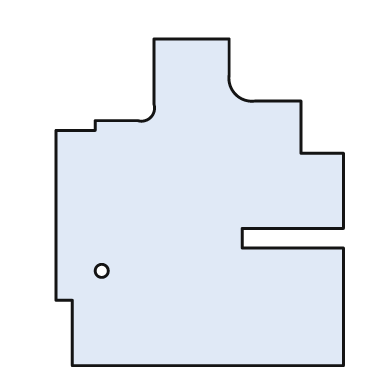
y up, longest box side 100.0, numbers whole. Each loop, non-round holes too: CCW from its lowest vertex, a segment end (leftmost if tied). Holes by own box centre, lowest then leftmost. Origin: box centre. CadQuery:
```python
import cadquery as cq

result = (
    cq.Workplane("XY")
    .moveTo(-39.0, -50.0)
    .lineTo(44.0, -50.0)
    .lineTo(44.0, -14.0)
    .lineTo(13.0, -14.0)
    .lineTo(13.0, -8.0)
    .lineTo(44.0, -8.0)
    .lineTo(44.0, 15.0)
    .lineTo(31.0, 15.0)
    .lineTo(31.0, 31.0)
    .lineTo(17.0, 31.0)
    .threePointArc((11.0, 33.0), (9.0, 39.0))
    .lineTo(9.0, 50.0)
    .lineTo(-14.0, 50.0)
    .lineTo(-14.0, 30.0)
    .threePointArc((-15.0, 26.0), (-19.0, 25.0))
    .lineTo(-32.0, 25.0)
    .lineTo(-32.0, 22.0)
    .lineTo(-44.0, 22.0)
    .lineTo(-44.0, -30.0)
    .lineTo(-39.0, -30.0)
    .close()
    .moveTo(-30.0, -21.0)
    .circle(2.0)
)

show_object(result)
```